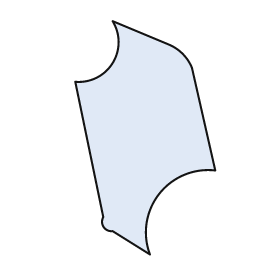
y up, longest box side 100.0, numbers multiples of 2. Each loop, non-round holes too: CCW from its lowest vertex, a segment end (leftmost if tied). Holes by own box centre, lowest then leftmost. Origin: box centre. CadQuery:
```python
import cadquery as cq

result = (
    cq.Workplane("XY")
    .moveTo(2.0, -50.0)
    .threePointArc((6.0, -24.0), (30.0, -14.0))
    .lineTo(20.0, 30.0)
    .threePointArc((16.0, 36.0), (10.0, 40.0))
    .lineTo(-14.0, 50.0)
    .threePointArc((-14.0, 32.0), (-30.0, 24.0))
    .lineTo(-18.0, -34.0)
    .threePointArc((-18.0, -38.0), (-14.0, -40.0))
    .close()
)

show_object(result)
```